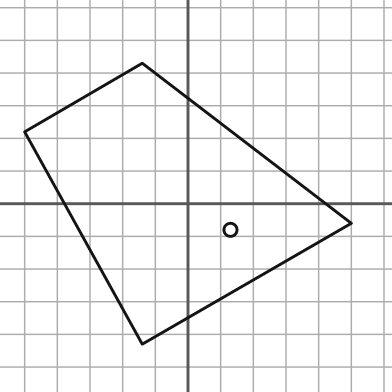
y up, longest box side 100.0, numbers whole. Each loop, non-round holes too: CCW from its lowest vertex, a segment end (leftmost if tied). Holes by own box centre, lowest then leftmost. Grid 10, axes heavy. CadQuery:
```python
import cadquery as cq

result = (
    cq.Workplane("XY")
    .moveTo(-14.0, -43.0)
    .lineTo(50.0, -6.0)
    .lineTo(-14.0, 43.0)
    .lineTo(-50.0, 22.0)
    .close()
    .moveTo(13.0, -8.0)
    .circle(2.0)
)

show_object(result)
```